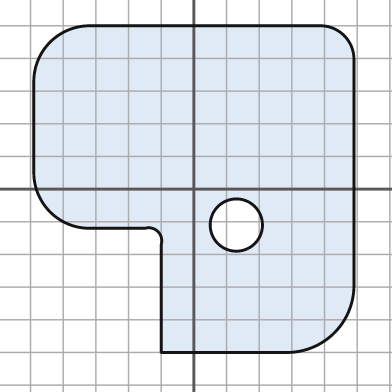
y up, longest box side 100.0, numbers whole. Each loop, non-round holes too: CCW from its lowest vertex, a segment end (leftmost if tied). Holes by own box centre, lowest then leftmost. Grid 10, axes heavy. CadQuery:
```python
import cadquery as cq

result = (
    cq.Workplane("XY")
    .moveTo(-10.0, -50.0)
    .lineTo(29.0, -50.0)
    .threePointArc((43.0, -44.0), (49.0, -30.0))
    .lineTo(49.0, 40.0)
    .threePointArc((46.0, 47.0), (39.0, 50.0))
    .lineTo(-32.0, 50.0)
    .threePointArc((-44.0, 45.0), (-49.0, 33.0))
    .lineTo(-49.0, 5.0)
    .threePointArc((-44.0, -7.0), (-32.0, -12.0))
    .lineTo(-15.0, -12.0)
    .threePointArc((-11.0, -13.0), (-10.0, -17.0))
    .close()
    .moveTo(13.0, -11.0)
    .circle(8.0)
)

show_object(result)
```